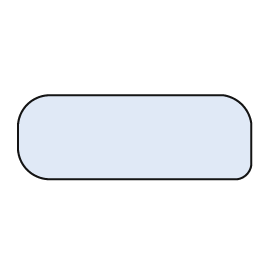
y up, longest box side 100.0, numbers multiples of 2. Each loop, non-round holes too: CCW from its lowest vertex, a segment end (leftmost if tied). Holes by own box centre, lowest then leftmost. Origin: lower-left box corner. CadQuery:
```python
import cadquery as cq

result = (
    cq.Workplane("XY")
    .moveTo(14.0, 0.0)
    .lineTo(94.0, 0.0)
    .threePointArc((98.0, 2.0), (100.0, 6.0))
    .lineTo(100.0, 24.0)
    .threePointArc((96.0, 32.0), (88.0, 36.0))
    .lineTo(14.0, 36.0)
    .threePointArc((4.0, 32.0), (0.0, 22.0))
    .lineTo(0.0, 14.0)
    .threePointArc((4.0, 4.0), (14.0, 0.0))
    .close()
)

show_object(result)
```